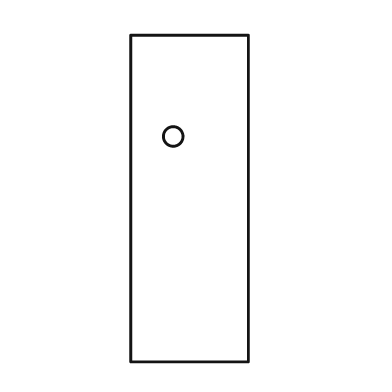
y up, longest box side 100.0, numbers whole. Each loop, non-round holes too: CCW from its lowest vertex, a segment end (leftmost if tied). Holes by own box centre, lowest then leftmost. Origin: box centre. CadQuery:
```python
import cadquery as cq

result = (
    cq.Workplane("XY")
    .moveTo(-18.0, -50.0)
    .lineTo(18.0, -50.0)
    .lineTo(18.0, 50.0)
    .lineTo(-18.0, 50.0)
    .close()
    .moveTo(-5.0, 19.0)
    .circle(3.0)
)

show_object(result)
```